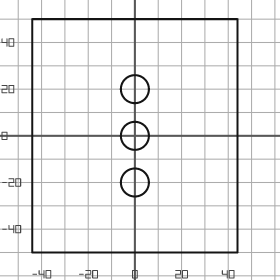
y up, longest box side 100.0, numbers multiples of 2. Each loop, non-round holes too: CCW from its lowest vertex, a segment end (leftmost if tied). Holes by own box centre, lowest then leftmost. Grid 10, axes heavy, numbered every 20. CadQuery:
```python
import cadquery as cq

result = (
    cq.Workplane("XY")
    .moveTo(-44.0, -50.0)
    .lineTo(44.0, -50.0)
    .lineTo(44.0, 50.0)
    .lineTo(-44.0, 50.0)
    .close()
    .moveTo(0.0, -20.0)
    .circle(6.0)
    .moveTo(0.0, 0.0)
    .circle(6.0)
    .moveTo(0.0, 20.0)
    .circle(6.0)
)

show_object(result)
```